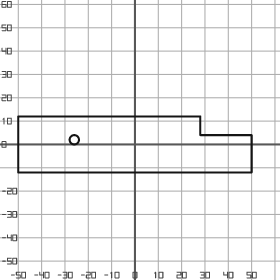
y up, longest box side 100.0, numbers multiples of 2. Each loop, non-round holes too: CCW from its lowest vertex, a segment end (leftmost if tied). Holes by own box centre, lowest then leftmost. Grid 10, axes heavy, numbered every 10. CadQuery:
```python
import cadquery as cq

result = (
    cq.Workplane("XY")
    .moveTo(-50.0, -12.0)
    .lineTo(50.0, -12.0)
    .lineTo(50.0, 4.0)
    .lineTo(28.0, 4.0)
    .lineTo(28.0, 12.0)
    .lineTo(-50.0, 12.0)
    .close()
    .moveTo(-26.0, 2.0)
    .circle(2.0)
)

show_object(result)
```